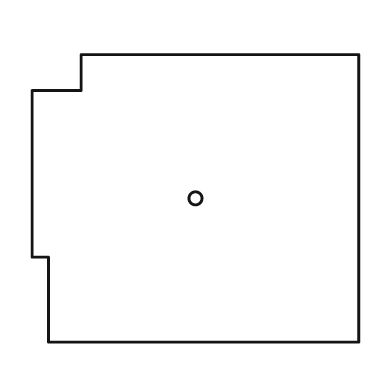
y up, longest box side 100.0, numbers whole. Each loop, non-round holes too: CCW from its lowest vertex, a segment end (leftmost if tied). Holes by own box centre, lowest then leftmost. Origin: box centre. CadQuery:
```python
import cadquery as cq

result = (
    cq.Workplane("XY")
    .moveTo(-45.0, -44.0)
    .lineTo(50.0, -44.0)
    .lineTo(50.0, 44.0)
    .lineTo(-35.0, 44.0)
    .lineTo(-35.0, 33.0)
    .lineTo(-50.0, 33.0)
    .lineTo(-50.0, -18.0)
    .lineTo(-45.0, -18.0)
    .close()
    .moveTo(0.0, 0.0)
    .circle(2.0)
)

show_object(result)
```